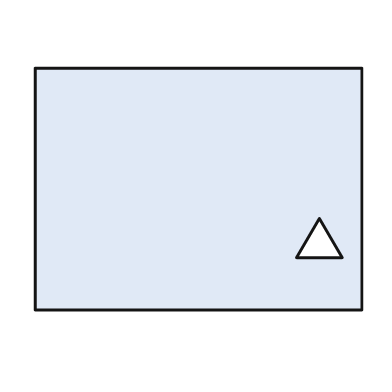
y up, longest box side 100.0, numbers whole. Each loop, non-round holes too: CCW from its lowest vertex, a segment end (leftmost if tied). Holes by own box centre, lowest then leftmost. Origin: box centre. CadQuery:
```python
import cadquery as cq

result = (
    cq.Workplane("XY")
    .moveTo(-50.0, -37.0)
    .lineTo(50.0, -37.0)
    .lineTo(50.0, 37.0)
    .lineTo(-50.0, 37.0)
    .close()
    .moveTo(30.0, -21.0)
    .lineTo(44.0, -21.0)
    .lineTo(37.0, -9.0)
    .close()
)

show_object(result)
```